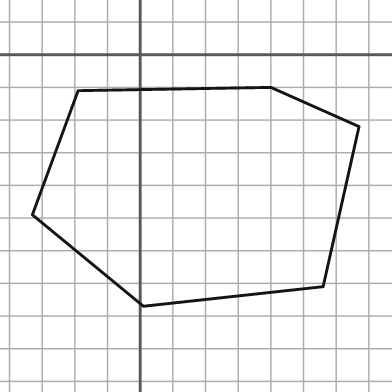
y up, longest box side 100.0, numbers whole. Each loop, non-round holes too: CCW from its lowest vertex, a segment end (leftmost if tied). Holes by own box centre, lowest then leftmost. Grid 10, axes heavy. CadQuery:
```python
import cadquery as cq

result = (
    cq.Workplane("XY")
    .moveTo(1.0, -77.0)
    .lineTo(56.0, -71.0)
    .lineTo(67.0, -22.0)
    .lineTo(40.0, -10.0)
    .lineTo(-19.0, -11.0)
    .lineTo(-33.0, -49.0)
    .close()
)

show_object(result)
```